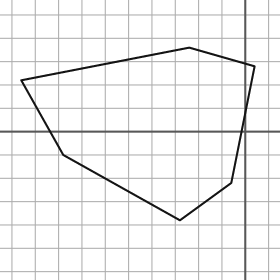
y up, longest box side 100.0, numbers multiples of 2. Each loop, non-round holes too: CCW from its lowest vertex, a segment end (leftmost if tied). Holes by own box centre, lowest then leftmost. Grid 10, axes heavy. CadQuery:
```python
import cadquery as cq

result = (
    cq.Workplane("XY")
    .moveTo(-28.0, -38.0)
    .lineTo(-6.0, -22.0)
    .lineTo(4.0, 28.0)
    .lineTo(-24.0, 36.0)
    .lineTo(-96.0, 22.0)
    .lineTo(-78.0, -10.0)
    .close()
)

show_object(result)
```